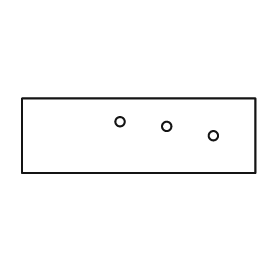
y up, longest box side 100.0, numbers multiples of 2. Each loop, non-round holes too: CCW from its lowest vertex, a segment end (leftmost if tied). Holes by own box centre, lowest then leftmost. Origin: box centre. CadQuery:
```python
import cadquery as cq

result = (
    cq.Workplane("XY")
    .moveTo(-50.0, -16.0)
    .lineTo(50.0, -16.0)
    .lineTo(50.0, 16.0)
    .lineTo(-50.0, 16.0)
    .close()
    .moveTo(32.0, 0.0)
    .circle(2.0)
    .moveTo(12.0, 4.0)
    .circle(2.0)
    .moveTo(-8.0, 6.0)
    .circle(2.0)
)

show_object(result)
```